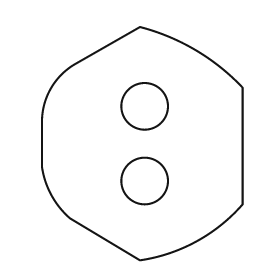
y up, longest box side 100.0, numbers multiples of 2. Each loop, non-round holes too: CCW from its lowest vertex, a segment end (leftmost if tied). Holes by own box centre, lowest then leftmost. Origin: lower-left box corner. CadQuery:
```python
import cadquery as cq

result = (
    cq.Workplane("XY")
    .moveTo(42.0, 0.0)
    .threePointArc((66.0, 8.0), (86.0, 24.0))
    .lineTo(86.0, 74.0)
    .threePointArc((66.0, 90.0), (42.0, 100.0))
    .lineTo(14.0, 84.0)
    .threePointArc((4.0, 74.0), (0.0, 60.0))
    .lineTo(0.0, 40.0)
    .threePointArc((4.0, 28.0), (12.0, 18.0))
    .close()
    .moveTo(44.0, 34.0)
    .circle(10.0)
    .moveTo(44.0, 66.0)
    .circle(10.0)
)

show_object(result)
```